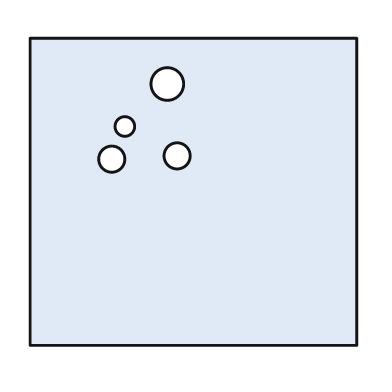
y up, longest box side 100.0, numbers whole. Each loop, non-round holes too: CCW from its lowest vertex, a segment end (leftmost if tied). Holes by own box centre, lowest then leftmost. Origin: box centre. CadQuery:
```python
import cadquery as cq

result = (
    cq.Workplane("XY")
    .moveTo(-50.0, -47.0)
    .lineTo(50.0, -47.0)
    .lineTo(50.0, 47.0)
    .lineTo(-50.0, 47.0)
    .close()
    .moveTo(-25.0, 10.0)
    .circle(4.0)
    .moveTo(-5.0, 11.0)
    .circle(4.0)
    .moveTo(-21.0, 20.0)
    .circle(3.0)
    .moveTo(-8.0, 33.0)
    .circle(5.0)
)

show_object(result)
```